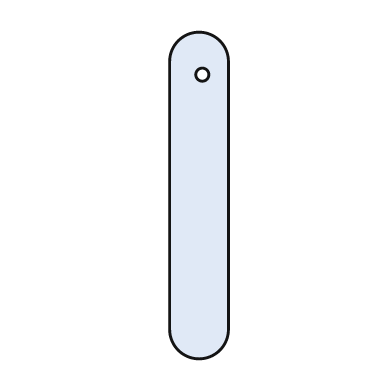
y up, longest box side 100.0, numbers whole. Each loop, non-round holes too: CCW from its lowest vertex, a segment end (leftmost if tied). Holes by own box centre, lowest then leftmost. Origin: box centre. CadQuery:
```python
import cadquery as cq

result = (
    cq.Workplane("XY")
    .moveTo(-9.0, -41.0)
    .threePointArc((0.0, -50.0), (9.0, -41.0))
    .lineTo(9.0, 41.0)
    .threePointArc((0.0, 50.0), (-9.0, 41.0))
    .close()
    .moveTo(1.0, 37.0)
    .circle(2.0)
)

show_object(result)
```